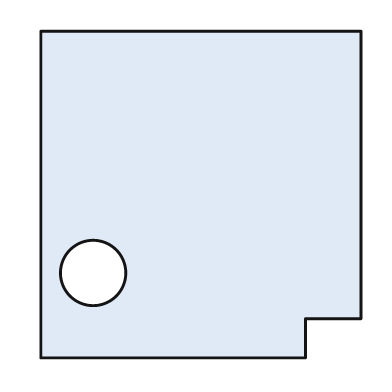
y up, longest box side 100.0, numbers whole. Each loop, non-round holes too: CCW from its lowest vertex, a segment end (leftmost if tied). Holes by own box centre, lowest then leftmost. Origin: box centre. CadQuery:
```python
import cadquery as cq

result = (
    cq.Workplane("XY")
    .moveTo(-49.0, -50.0)
    .lineTo(32.0, -50.0)
    .lineTo(32.0, -38.0)
    .lineTo(49.0, -38.0)
    .lineTo(49.0, 50.0)
    .lineTo(-49.0, 50.0)
    .close()
    .moveTo(-33.0, -24.0)
    .circle(10.0)
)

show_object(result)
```